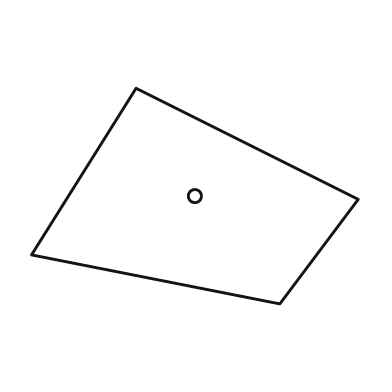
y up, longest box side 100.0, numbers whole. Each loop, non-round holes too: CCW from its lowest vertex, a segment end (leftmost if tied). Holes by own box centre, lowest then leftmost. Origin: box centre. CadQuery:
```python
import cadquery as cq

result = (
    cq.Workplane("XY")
    .moveTo(26.0, -33.0)
    .lineTo(50.0, -1.0)
    .lineTo(-18.0, 33.0)
    .lineTo(-50.0, -18.0)
    .close()
    .moveTo(0.0, 0.0)
    .circle(2.0)
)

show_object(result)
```